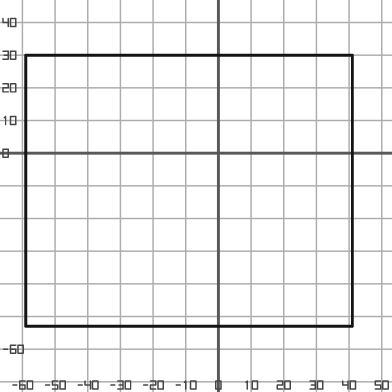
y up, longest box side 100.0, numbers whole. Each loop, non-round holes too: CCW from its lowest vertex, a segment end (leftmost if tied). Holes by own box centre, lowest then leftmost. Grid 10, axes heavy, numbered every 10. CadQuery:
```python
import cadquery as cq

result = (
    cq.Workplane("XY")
    .moveTo(-59.0, -53.0)
    .lineTo(41.0, -53.0)
    .lineTo(41.0, 30.0)
    .lineTo(-59.0, 30.0)
    .close()
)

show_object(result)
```